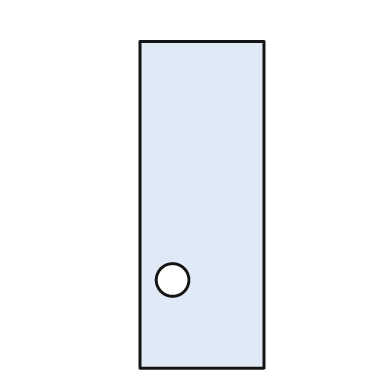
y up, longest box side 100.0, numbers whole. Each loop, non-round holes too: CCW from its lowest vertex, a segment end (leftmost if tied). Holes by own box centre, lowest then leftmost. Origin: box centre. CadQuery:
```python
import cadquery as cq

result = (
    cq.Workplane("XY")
    .moveTo(-19.0, -50.0)
    .lineTo(19.0, -50.0)
    .lineTo(19.0, 50.0)
    .lineTo(-19.0, 50.0)
    .close()
    .moveTo(-9.0, -23.0)
    .circle(5.0)
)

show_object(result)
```